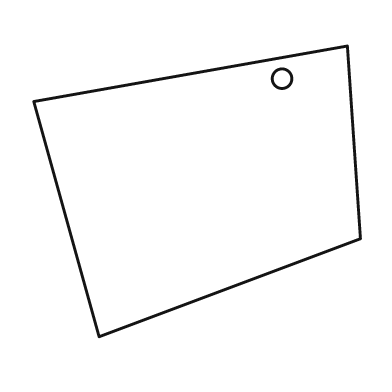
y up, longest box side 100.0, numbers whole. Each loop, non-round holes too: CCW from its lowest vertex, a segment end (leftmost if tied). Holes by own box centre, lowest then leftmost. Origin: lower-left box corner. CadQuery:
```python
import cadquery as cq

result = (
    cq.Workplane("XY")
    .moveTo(20.0, 0.0)
    .lineTo(100.0, 30.0)
    .lineTo(96.0, 89.0)
    .lineTo(0.0, 72.0)
    .close()
    .moveTo(76.0, 79.0)
    .circle(3.0)
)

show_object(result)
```